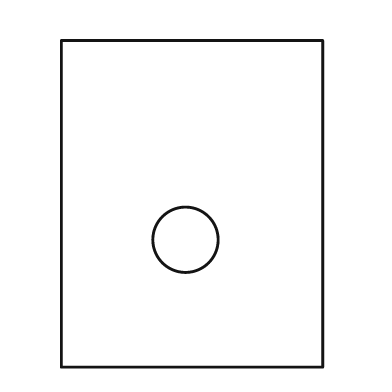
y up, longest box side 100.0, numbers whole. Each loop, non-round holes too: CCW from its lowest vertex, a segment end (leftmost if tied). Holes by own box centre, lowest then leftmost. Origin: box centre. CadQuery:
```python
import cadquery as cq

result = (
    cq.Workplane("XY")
    .moveTo(-40.0, -50.0)
    .lineTo(40.0, -50.0)
    .lineTo(40.0, 50.0)
    .lineTo(-40.0, 50.0)
    .close()
    .moveTo(-2.0, -11.0)
    .circle(10.0)
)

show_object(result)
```